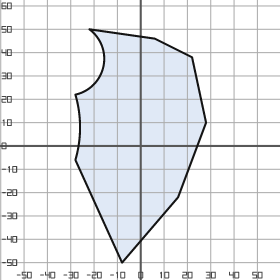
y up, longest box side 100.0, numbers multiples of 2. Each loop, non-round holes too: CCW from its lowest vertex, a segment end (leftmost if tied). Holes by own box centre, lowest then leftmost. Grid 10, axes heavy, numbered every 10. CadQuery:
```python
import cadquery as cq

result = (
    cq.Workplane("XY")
    .moveTo(-8.0, -50.0)
    .lineTo(16.0, -22.0)
    .lineTo(28.0, 10.0)
    .lineTo(22.0, 38.0)
    .lineTo(6.0, 46.0)
    .lineTo(-22.0, 50.0)
    .threePointArc((-16.0, 34.0), (-28.0, 22.0))
    .threePointArc((-26.0, 8.0), (-28.0, -6.0))
    .close()
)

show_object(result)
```